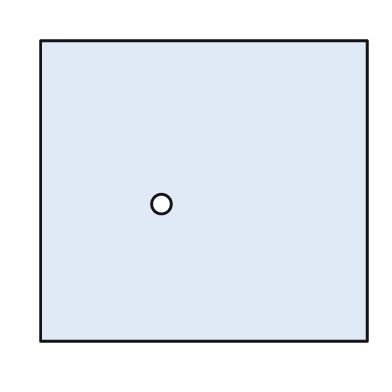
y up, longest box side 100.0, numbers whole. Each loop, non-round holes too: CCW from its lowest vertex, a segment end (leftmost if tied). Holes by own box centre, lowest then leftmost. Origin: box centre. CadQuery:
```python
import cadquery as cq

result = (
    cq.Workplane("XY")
    .moveTo(-50.0, -46.0)
    .lineTo(50.0, -46.0)
    .lineTo(50.0, 46.0)
    .lineTo(-50.0, 46.0)
    .close()
    .moveTo(-13.0, -4.0)
    .circle(3.0)
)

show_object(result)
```